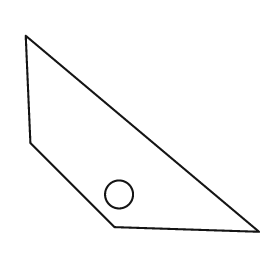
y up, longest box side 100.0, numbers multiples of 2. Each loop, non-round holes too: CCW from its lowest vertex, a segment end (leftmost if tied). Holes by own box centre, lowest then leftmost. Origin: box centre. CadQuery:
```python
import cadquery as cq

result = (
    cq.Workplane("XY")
    .moveTo(50.0, -42.0)
    .lineTo(-50.0, 42.0)
    .lineTo(-48.0, -4.0)
    .lineTo(-12.0, -40.0)
    .close()
    .moveTo(-10.0, -26.0)
    .circle(6.0)
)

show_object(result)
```